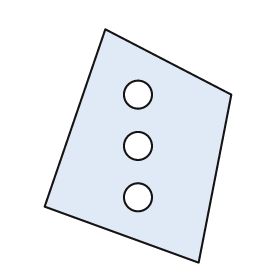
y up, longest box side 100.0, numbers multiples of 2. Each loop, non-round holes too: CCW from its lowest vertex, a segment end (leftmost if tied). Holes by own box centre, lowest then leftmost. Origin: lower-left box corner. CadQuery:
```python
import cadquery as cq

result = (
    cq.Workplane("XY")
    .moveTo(66.0, 0.0)
    .lineTo(80.0, 72.0)
    .lineTo(26.0, 100.0)
    .lineTo(0.0, 24.0)
    .close()
    .moveTo(40.0, 28.0)
    .circle(6.0)
    .moveTo(40.0, 50.0)
    .circle(6.0)
    .moveTo(40.0, 72.0)
    .circle(6.0)
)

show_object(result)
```